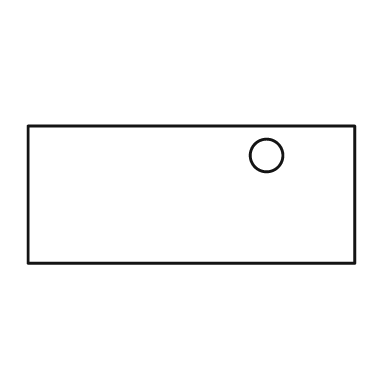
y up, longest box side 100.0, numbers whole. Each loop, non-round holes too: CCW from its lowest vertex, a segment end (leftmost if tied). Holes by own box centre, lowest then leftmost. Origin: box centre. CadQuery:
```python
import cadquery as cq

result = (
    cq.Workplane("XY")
    .moveTo(-50.0, -21.0)
    .lineTo(50.0, -21.0)
    .lineTo(50.0, 21.0)
    .lineTo(-50.0, 21.0)
    .close()
    .moveTo(23.0, 12.0)
    .circle(5.0)
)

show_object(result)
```